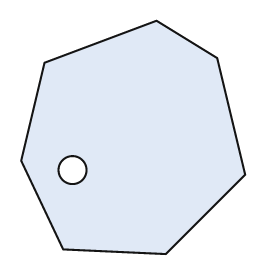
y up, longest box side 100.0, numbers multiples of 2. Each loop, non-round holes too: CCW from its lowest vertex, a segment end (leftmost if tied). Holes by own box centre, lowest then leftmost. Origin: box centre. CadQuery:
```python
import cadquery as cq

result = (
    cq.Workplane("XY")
    .moveTo(14.0, -50.0)
    .lineTo(48.0, -16.0)
    .lineTo(36.0, 34.0)
    .lineTo(10.0, 50.0)
    .lineTo(-38.0, 32.0)
    .lineTo(-48.0, -10.0)
    .lineTo(-30.0, -48.0)
    .close()
    .moveTo(-26.0, -14.0)
    .circle(6.0)
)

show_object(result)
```